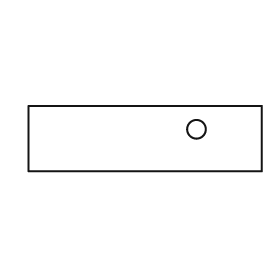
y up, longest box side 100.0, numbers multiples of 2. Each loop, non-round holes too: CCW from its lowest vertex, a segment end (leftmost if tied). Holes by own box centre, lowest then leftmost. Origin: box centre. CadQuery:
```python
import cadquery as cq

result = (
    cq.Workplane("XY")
    .moveTo(-50.0, -14.0)
    .lineTo(50.0, -14.0)
    .lineTo(50.0, 14.0)
    .lineTo(-50.0, 14.0)
    .close()
    .moveTo(22.0, 4.0)
    .circle(4.0)
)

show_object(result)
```